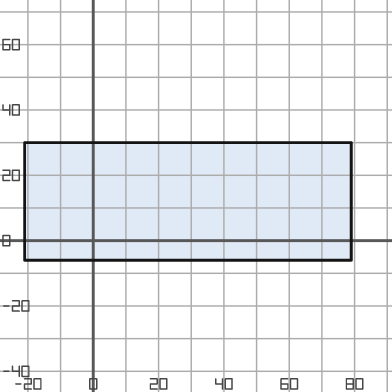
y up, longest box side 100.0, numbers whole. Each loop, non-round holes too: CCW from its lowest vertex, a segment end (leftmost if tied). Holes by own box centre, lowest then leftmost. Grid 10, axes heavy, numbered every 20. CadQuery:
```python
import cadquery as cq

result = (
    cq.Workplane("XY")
    .moveTo(-21.0, -6.0)
    .lineTo(79.0, -6.0)
    .lineTo(79.0, 30.0)
    .lineTo(-21.0, 30.0)
    .close()
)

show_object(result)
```